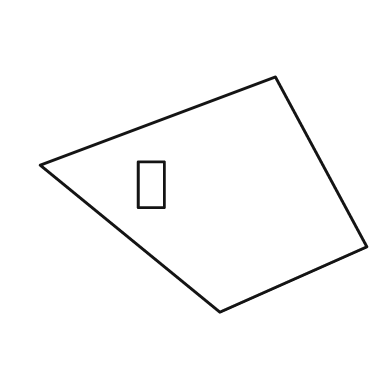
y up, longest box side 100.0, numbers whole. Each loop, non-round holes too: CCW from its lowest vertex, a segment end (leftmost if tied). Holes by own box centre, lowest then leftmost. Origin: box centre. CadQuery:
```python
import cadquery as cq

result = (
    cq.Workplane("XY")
    .moveTo(5.0, -36.0)
    .lineTo(50.0, -16.0)
    .lineTo(22.0, 36.0)
    .lineTo(-50.0, 9.0)
    .close()
    .moveTo(-20.0, -4.0)
    .lineTo(-12.0, -4.0)
    .lineTo(-12.0, 10.0)
    .lineTo(-20.0, 10.0)
    .close()
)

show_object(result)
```